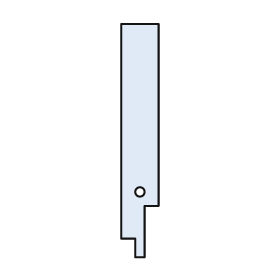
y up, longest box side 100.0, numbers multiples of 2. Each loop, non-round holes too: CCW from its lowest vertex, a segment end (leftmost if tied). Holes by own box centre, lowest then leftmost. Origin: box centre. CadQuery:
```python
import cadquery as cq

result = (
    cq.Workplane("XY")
    .moveTo(-2.0, -50.0)
    .lineTo(2.0, -50.0)
    .lineTo(2.0, -28.0)
    .lineTo(8.0, -28.0)
    .lineTo(8.0, 50.0)
    .lineTo(-8.0, 50.0)
    .lineTo(-8.0, -42.0)
    .lineTo(-2.0, -42.0)
    .close()
    .moveTo(0.0, -22.0)
    .circle(2.0)
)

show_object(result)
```